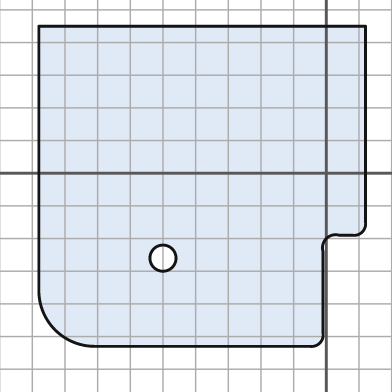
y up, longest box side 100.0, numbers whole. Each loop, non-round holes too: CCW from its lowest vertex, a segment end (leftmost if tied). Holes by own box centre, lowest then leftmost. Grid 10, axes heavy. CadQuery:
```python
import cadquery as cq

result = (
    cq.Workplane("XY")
    .moveTo(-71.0, -53.0)
    .lineTo(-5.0, -53.0)
    .threePointArc((-2.0, -52.0), (-1.0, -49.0))
    .lineTo(-1.0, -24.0)
    .threePointArc((0.0, -20.0), (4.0, -19.0))
    .lineTo(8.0, -19.0)
    .threePointArc((11.0, -18.0), (12.0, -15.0))
    .lineTo(12.0, 45.0)
    .lineTo(-88.0, 45.0)
    .lineTo(-88.0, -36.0)
    .threePointArc((-83.0, -48.0), (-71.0, -53.0))
    .close()
    .moveTo(-50.0, -26.0)
    .circle(4.0)
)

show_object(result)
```